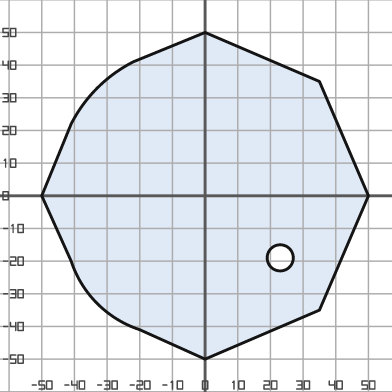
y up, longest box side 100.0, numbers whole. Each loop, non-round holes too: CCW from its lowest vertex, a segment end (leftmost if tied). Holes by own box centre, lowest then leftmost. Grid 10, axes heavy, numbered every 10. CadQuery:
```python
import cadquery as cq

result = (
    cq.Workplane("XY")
    .moveTo(0.0, -50.0)
    .lineTo(35.0, -35.0)
    .lineTo(50.0, 0.0)
    .lineTo(35.0, 35.0)
    .lineTo(0.0, 50.0)
    .lineTo(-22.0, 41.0)
    .threePointArc((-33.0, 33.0), (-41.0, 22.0))
    .lineTo(-50.0, 0.0)
    .lineTo(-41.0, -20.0)
    .threePointArc((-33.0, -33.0), (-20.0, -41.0))
    .close()
    .moveTo(23.0, -19.0)
    .circle(4.0)
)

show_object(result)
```